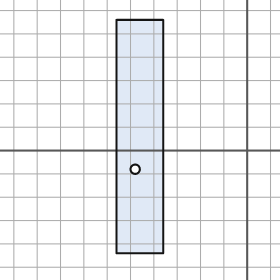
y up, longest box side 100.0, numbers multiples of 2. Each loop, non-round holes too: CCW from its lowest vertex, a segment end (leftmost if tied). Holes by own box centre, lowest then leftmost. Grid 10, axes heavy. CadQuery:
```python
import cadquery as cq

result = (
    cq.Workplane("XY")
    .moveTo(-56.0, -44.0)
    .lineTo(-36.0, -44.0)
    .lineTo(-36.0, 56.0)
    .lineTo(-56.0, 56.0)
    .close()
    .moveTo(-48.0, -8.0)
    .circle(2.0)
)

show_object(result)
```